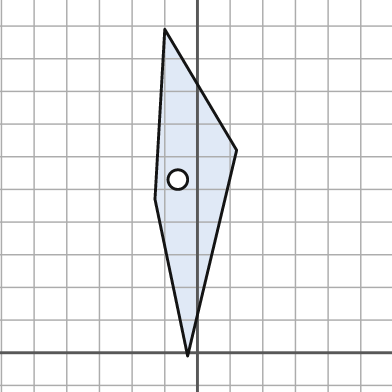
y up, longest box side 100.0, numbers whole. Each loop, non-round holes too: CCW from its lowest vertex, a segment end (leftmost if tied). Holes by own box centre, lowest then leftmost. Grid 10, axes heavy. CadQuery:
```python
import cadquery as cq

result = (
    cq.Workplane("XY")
    .moveTo(-3.0, -1.0)
    .lineTo(12.0, 62.0)
    .lineTo(-10.0, 99.0)
    .lineTo(-13.0, 47.0)
    .close()
    .moveTo(-6.0, 53.0)
    .circle(3.0)
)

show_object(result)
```